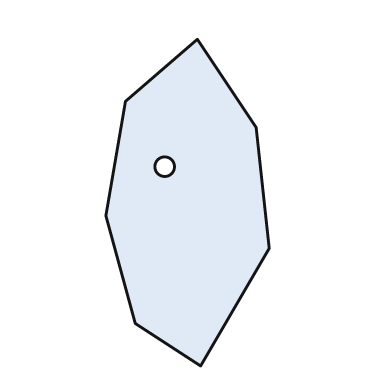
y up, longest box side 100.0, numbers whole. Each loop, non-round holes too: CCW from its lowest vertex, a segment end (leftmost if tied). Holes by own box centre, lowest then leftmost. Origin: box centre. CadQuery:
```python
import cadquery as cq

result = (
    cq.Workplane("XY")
    .moveTo(4.0, -50.0)
    .lineTo(25.0, -14.0)
    .lineTo(21.0, 23.0)
    .lineTo(3.0, 50.0)
    .lineTo(-19.0, 31.0)
    .lineTo(-25.0, -4.0)
    .lineTo(-16.0, -37.0)
    .close()
    .moveTo(-7.0, 11.0)
    .circle(3.0)
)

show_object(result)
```